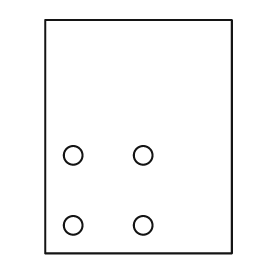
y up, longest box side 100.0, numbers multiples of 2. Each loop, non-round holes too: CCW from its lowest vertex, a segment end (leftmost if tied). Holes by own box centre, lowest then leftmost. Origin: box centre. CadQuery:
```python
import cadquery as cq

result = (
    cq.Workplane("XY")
    .moveTo(-40.0, -50.0)
    .lineTo(40.0, -50.0)
    .lineTo(40.0, 50.0)
    .lineTo(-40.0, 50.0)
    .close()
    .moveTo(-28.0, -38.0)
    .circle(4.0)
    .moveTo(2.0, -38.0)
    .circle(4.0)
    .moveTo(-28.0, -8.0)
    .circle(4.0)
    .moveTo(2.0, -8.0)
    .circle(4.0)
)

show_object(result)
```